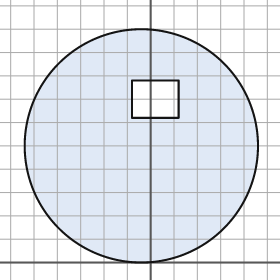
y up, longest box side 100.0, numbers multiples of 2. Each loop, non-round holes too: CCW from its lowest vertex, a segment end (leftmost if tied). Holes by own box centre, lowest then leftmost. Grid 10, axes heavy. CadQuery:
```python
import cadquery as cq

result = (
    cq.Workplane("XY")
    .moveTo(-4.0, 50.0)
    .circle(50.0)
    .moveTo(-8.0, 62.0)
    .lineTo(12.0, 62.0)
    .lineTo(12.0, 78.0)
    .lineTo(-8.0, 78.0)
    .close()
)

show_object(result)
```